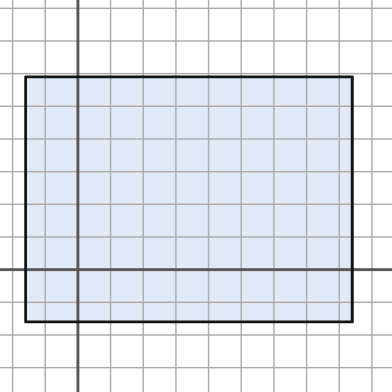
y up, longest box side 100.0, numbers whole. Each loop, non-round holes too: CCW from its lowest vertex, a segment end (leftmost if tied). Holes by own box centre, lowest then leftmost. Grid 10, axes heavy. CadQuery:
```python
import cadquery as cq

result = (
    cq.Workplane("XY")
    .moveTo(-16.0, -16.0)
    .lineTo(84.0, -16.0)
    .lineTo(84.0, 59.0)
    .lineTo(-16.0, 59.0)
    .close()
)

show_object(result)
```